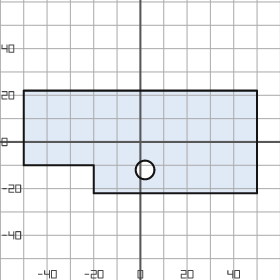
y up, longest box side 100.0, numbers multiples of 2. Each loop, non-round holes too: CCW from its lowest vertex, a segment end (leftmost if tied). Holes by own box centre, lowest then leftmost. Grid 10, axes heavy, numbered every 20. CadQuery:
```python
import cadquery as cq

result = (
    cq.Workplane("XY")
    .moveTo(-20.0, -22.0)
    .lineTo(50.0, -22.0)
    .lineTo(50.0, 22.0)
    .lineTo(-50.0, 22.0)
    .lineTo(-50.0, -10.0)
    .lineTo(-20.0, -10.0)
    .close()
    .moveTo(2.0, -12.0)
    .circle(4.0)
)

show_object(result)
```